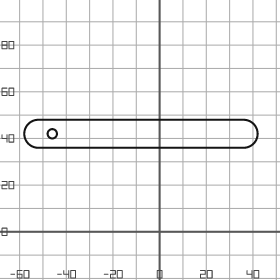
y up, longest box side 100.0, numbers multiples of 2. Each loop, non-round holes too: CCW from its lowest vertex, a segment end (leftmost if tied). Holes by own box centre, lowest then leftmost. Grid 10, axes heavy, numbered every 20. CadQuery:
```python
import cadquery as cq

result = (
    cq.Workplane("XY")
    .moveTo(-52.0, 36.0)
    .lineTo(36.0, 36.0)
    .threePointArc((42.0, 42.0), (36.0, 48.0))
    .lineTo(-52.0, 48.0)
    .threePointArc((-58.0, 42.0), (-52.0, 36.0))
    .close()
    .moveTo(-46.0, 42.0)
    .circle(2.0)
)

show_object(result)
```